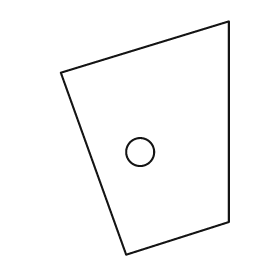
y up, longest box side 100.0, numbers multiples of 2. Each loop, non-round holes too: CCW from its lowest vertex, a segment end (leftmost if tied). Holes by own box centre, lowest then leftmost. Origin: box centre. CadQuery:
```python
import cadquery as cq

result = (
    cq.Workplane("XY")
    .moveTo(-8.0, -50.0)
    .lineTo(36.0, -36.0)
    .lineTo(36.0, 50.0)
    .lineTo(-36.0, 28.0)
    .close()
    .moveTo(-2.0, -6.0)
    .circle(6.0)
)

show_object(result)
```